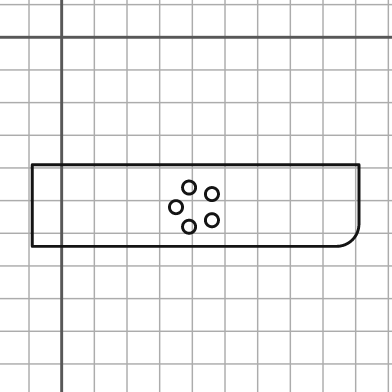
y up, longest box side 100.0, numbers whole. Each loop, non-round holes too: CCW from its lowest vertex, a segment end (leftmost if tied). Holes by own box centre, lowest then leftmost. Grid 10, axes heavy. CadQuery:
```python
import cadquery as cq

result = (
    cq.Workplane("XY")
    .moveTo(-9.0, -64.0)
    .lineTo(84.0, -64.0)
    .threePointArc((89.0, -62.0), (91.0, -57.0))
    .lineTo(91.0, -39.0)
    .lineTo(-9.0, -39.0)
    .close()
    .moveTo(39.0, -58.0)
    .circle(2.0)
    .moveTo(46.0, -56.0)
    .circle(2.0)
    .moveTo(35.0, -52.0)
    .circle(2.0)
    .moveTo(46.0, -48.0)
    .circle(2.0)
    .moveTo(39.0, -46.0)
    .circle(2.0)
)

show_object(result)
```